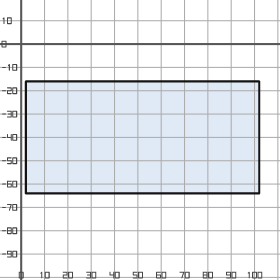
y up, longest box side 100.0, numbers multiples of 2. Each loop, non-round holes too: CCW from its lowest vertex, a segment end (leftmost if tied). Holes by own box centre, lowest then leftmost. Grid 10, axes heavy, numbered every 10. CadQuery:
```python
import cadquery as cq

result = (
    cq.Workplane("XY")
    .moveTo(2.0, -64.0)
    .lineTo(102.0, -64.0)
    .lineTo(102.0, -16.0)
    .lineTo(2.0, -16.0)
    .close()
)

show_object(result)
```